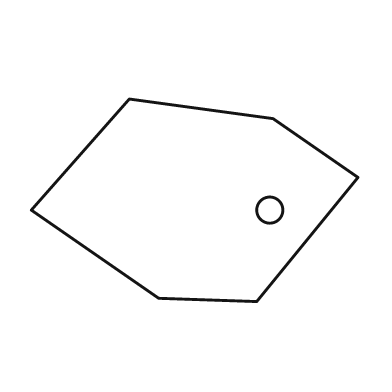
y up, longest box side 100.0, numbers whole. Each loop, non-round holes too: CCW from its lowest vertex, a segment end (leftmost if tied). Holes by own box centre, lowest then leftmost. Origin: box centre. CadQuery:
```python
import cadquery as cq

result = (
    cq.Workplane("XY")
    .moveTo(19.0, -31.0)
    .lineTo(50.0, 7.0)
    .lineTo(24.0, 25.0)
    .lineTo(-20.0, 31.0)
    .lineTo(-50.0, -3.0)
    .lineTo(-11.0, -30.0)
    .close()
    .moveTo(23.0, -3.0)
    .circle(4.0)
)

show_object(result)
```